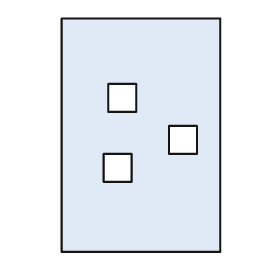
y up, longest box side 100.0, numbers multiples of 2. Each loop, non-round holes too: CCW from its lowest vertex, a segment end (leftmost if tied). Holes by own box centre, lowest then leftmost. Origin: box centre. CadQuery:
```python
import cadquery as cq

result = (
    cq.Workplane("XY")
    .moveTo(-34.0, -50.0)
    .lineTo(34.0, -50.0)
    .lineTo(34.0, 50.0)
    .lineTo(-34.0, 50.0)
    .close()
    .moveTo(-16.0, -20.0)
    .lineTo(-4.0, -20.0)
    .lineTo(-4.0, -8.0)
    .lineTo(-16.0, -8.0)
    .close()
    .moveTo(12.0, -8.0)
    .lineTo(24.0, -8.0)
    .lineTo(24.0, 4.0)
    .lineTo(12.0, 4.0)
    .close()
    .moveTo(-14.0, 10.0)
    .lineTo(-2.0, 10.0)
    .lineTo(-2.0, 22.0)
    .lineTo(-14.0, 22.0)
    .close()
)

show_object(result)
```